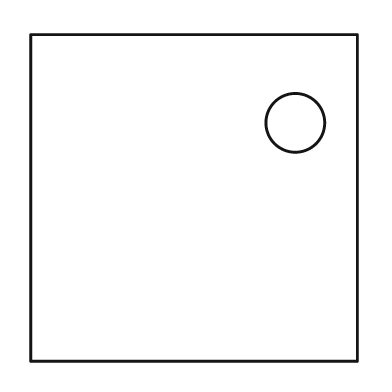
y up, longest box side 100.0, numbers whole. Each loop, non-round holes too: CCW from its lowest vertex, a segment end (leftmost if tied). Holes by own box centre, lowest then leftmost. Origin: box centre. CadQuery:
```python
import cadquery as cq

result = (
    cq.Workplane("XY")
    .moveTo(-50.0, -50.0)
    .lineTo(50.0, -50.0)
    .lineTo(50.0, 50.0)
    .lineTo(-50.0, 50.0)
    .close()
    .moveTo(31.0, 23.0)
    .circle(9.0)
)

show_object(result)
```